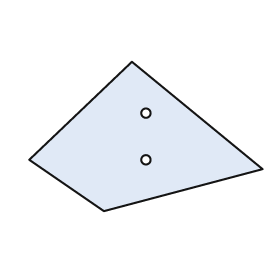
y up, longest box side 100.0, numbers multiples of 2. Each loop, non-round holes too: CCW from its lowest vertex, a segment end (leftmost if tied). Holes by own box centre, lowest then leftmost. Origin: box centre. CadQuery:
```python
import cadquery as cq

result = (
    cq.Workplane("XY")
    .moveTo(-18.0, -32.0)
    .lineTo(50.0, -14.0)
    .lineTo(-6.0, 32.0)
    .lineTo(-50.0, -10.0)
    .close()
    .moveTo(0.0, -10.0)
    .circle(2.0)
    .moveTo(0.0, 10.0)
    .circle(2.0)
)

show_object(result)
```